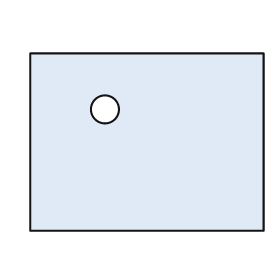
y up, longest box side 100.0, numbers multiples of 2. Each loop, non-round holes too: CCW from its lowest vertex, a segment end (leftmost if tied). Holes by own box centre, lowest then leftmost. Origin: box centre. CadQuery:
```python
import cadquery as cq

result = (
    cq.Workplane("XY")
    .moveTo(-50.0, -38.0)
    .lineTo(50.0, -38.0)
    .lineTo(50.0, 38.0)
    .lineTo(-50.0, 38.0)
    .close()
    .moveTo(-18.0, 14.0)
    .circle(6.0)
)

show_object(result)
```